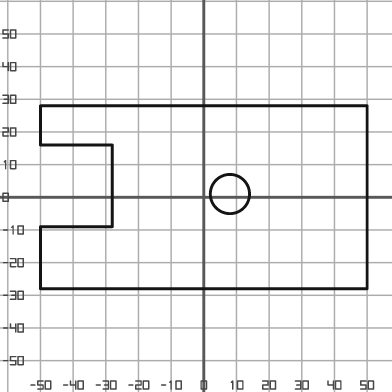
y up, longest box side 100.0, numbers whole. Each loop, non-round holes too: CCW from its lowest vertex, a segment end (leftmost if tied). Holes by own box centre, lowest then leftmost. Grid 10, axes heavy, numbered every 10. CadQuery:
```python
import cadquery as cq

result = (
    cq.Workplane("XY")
    .moveTo(-50.0, -28.0)
    .lineTo(50.0, -28.0)
    .lineTo(50.0, 28.0)
    .lineTo(-50.0, 28.0)
    .lineTo(-50.0, 16.0)
    .lineTo(-28.0, 16.0)
    .lineTo(-28.0, -9.0)
    .lineTo(-50.0, -9.0)
    .close()
    .moveTo(8.0, 1.0)
    .circle(6.0)
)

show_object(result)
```